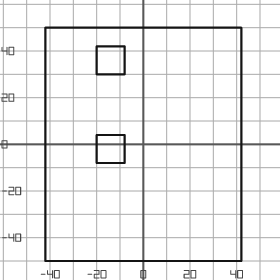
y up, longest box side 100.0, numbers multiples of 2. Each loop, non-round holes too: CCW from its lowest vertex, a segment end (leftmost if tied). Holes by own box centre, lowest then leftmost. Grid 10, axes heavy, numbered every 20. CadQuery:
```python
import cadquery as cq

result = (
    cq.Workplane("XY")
    .moveTo(-42.0, -50.0)
    .lineTo(42.0, -50.0)
    .lineTo(42.0, 50.0)
    .lineTo(-42.0, 50.0)
    .close()
    .moveTo(-20.0, -8.0)
    .lineTo(-8.0, -8.0)
    .lineTo(-8.0, 4.0)
    .lineTo(-20.0, 4.0)
    .close()
    .moveTo(-20.0, 30.0)
    .lineTo(-8.0, 30.0)
    .lineTo(-8.0, 42.0)
    .lineTo(-20.0, 42.0)
    .close()
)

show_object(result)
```